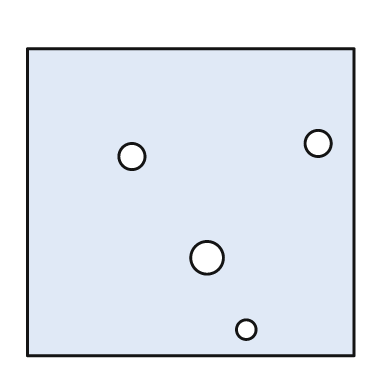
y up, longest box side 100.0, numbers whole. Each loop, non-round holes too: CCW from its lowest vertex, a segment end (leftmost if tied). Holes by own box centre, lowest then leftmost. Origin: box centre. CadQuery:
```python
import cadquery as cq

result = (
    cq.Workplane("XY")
    .moveTo(-50.0, -47.0)
    .lineTo(50.0, -47.0)
    .lineTo(50.0, 47.0)
    .lineTo(-50.0, 47.0)
    .close()
    .moveTo(17.0, -39.0)
    .circle(3.0)
    .moveTo(5.0, -17.0)
    .circle(5.0)
    .moveTo(-18.0, 14.0)
    .circle(4.0)
    .moveTo(39.0, 18.0)
    .circle(4.0)
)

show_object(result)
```